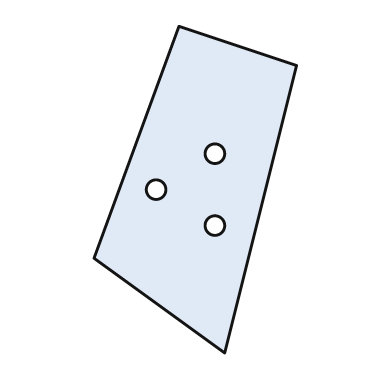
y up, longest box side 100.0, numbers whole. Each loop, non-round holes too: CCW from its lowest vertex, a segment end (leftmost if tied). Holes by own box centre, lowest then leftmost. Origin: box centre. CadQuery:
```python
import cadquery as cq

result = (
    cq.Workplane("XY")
    .moveTo(9.0, -50.0)
    .lineTo(31.0, 38.0)
    .lineTo(-5.0, 50.0)
    .lineTo(-31.0, -21.0)
    .close()
    .moveTo(6.0, -11.0)
    .circle(3.0)
    .moveTo(-12.0, 0.0)
    .circle(3.0)
    .moveTo(6.0, 11.0)
    .circle(3.0)
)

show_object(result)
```